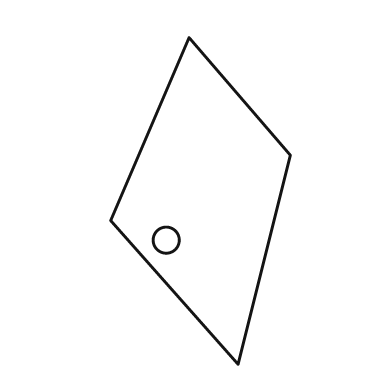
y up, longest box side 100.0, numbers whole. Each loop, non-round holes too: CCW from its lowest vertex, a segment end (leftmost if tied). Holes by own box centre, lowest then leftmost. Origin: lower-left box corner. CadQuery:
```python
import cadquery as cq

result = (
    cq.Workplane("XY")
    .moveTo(39.0, 0.0)
    .lineTo(55.0, 64.0)
    .lineTo(24.0, 100.0)
    .lineTo(0.0, 44.0)
    .close()
    .moveTo(17.0, 38.0)
    .circle(4.0)
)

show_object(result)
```